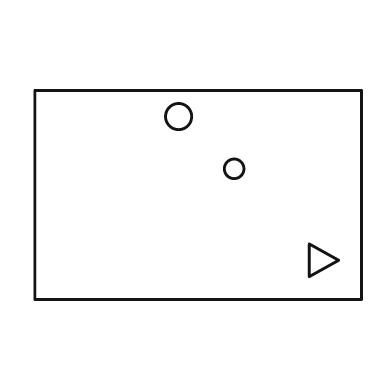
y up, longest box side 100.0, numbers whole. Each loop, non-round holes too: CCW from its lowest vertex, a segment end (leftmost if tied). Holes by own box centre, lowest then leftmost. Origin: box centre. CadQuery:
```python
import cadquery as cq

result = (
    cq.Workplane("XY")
    .moveTo(-50.0, -32.0)
    .lineTo(50.0, -32.0)
    .lineTo(50.0, 32.0)
    .lineTo(-50.0, 32.0)
    .close()
    .moveTo(34.0, -25.0)
    .lineTo(43.0, -20.0)
    .lineTo(34.0, -15.0)
    .close()
    .moveTo(11.0, 8.0)
    .circle(3.0)
    .moveTo(-6.0, 24.0)
    .circle(4.0)
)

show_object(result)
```